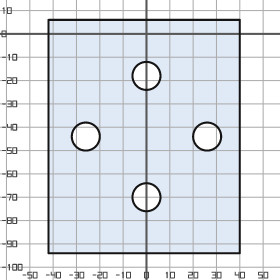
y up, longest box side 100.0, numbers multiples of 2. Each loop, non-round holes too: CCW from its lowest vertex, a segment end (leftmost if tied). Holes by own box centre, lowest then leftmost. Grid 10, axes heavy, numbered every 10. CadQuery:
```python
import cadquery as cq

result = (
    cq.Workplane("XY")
    .moveTo(-42.0, -94.0)
    .lineTo(40.0, -94.0)
    .lineTo(40.0, 6.0)
    .lineTo(-42.0, 6.0)
    .close()
    .moveTo(0.0, -70.0)
    .circle(6.0)
    .moveTo(-26.0, -44.0)
    .circle(6.0)
    .moveTo(26.0, -44.0)
    .circle(6.0)
    .moveTo(0.0, -18.0)
    .circle(6.0)
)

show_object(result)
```